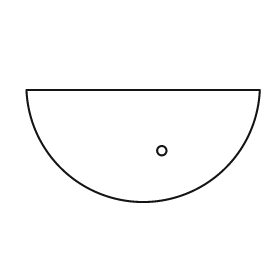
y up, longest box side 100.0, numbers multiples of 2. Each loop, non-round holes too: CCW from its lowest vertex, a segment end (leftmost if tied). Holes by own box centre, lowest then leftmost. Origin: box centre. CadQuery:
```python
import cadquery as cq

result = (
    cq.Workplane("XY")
    .moveTo(-50.0, 24.0)
    .threePointArc((0.0, -24.0), (50.0, 24.0))
    .close()
    .moveTo(8.0, -2.0)
    .circle(2.0)
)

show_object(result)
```